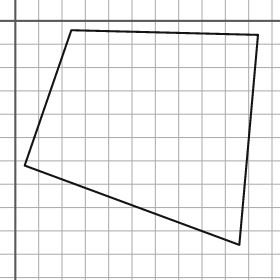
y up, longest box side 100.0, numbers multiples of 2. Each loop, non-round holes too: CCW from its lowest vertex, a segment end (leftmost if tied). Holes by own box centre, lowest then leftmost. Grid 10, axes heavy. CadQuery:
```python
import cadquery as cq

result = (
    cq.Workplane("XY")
    .moveTo(96.0, -96.0)
    .lineTo(104.0, -6.0)
    .lineTo(24.0, -4.0)
    .lineTo(4.0, -62.0)
    .close()
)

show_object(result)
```